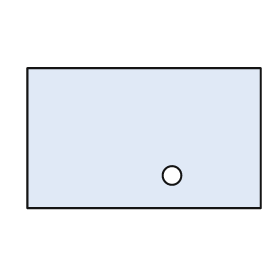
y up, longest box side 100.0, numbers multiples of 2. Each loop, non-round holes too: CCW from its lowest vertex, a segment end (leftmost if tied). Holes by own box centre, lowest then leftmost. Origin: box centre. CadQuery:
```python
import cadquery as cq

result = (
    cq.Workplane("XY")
    .moveTo(-50.0, -30.0)
    .lineTo(50.0, -30.0)
    .lineTo(50.0, 30.0)
    .lineTo(-50.0, 30.0)
    .close()
    .moveTo(12.0, -16.0)
    .circle(4.0)
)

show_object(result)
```